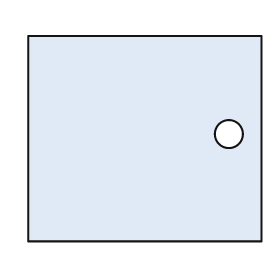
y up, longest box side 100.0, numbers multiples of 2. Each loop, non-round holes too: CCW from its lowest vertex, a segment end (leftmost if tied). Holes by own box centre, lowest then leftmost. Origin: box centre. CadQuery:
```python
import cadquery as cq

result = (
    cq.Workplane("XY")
    .moveTo(-50.0, -44.0)
    .lineTo(50.0, -44.0)
    .lineTo(50.0, 44.0)
    .lineTo(-50.0, 44.0)
    .close()
    .moveTo(36.0, 2.0)
    .circle(6.0)
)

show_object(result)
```